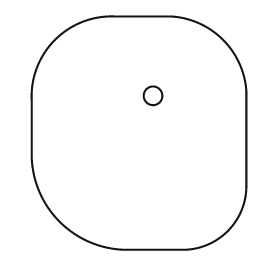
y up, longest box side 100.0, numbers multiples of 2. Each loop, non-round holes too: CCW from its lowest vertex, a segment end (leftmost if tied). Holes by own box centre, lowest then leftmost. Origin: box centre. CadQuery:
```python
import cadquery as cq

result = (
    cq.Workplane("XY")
    .moveTo(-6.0, -50.0)
    .lineTo(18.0, -50.0)
    .threePointArc((38.0, -42.0), (46.0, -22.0))
    .lineTo(46.0, 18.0)
    .threePointArc((36.0, 40.0), (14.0, 50.0))
    .lineTo(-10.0, 50.0)
    .threePointArc((-36.0, 40.0), (-46.0, 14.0))
    .lineTo(-46.0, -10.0)
    .threePointArc((-34.0, -38.0), (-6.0, -50.0))
    .close()
    .moveTo(6.0, 16.0)
    .circle(4.0)
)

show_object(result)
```